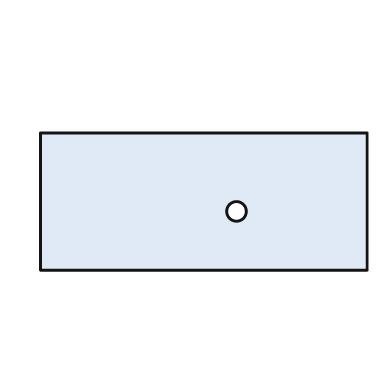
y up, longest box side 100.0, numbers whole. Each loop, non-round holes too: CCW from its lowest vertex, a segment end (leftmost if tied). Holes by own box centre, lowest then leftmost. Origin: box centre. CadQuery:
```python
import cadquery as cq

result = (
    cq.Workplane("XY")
    .moveTo(-50.0, -21.0)
    .lineTo(50.0, -21.0)
    .lineTo(50.0, 21.0)
    .lineTo(-50.0, 21.0)
    .close()
    .moveTo(10.0, -3.0)
    .circle(3.0)
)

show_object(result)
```